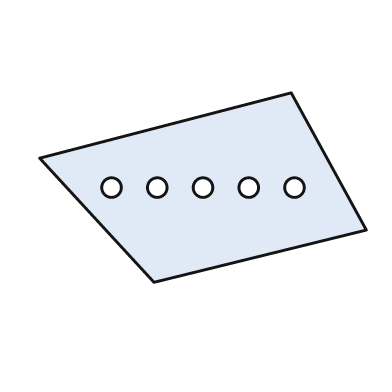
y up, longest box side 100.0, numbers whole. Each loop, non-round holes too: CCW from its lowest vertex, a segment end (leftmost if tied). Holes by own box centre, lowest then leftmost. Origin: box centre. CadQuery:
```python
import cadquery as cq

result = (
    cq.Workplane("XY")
    .moveTo(-15.0, -29.0)
    .lineTo(50.0, -13.0)
    .lineTo(27.0, 29.0)
    .lineTo(-50.0, 9.0)
    .close()
    .moveTo(-28.0, 0.0)
    .circle(3.0)
    .moveTo(-14.0, 0.0)
    .circle(3.0)
    .moveTo(0.0, 0.0)
    .circle(3.0)
    .moveTo(14.0, 0.0)
    .circle(3.0)
    .moveTo(28.0, 0.0)
    .circle(3.0)
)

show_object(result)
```